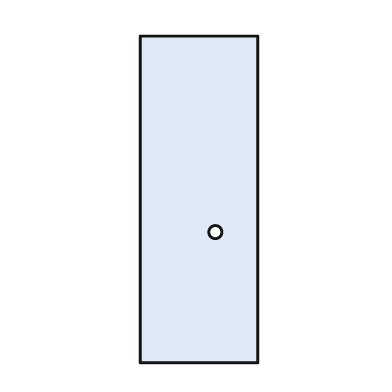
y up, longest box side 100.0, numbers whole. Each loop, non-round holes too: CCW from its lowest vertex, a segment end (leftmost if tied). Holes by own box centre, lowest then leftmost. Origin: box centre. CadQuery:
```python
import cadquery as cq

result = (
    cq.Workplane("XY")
    .moveTo(-18.0, -50.0)
    .lineTo(18.0, -50.0)
    .lineTo(18.0, 50.0)
    .lineTo(-18.0, 50.0)
    .close()
    .moveTo(5.0, -10.0)
    .circle(2.0)
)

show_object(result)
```